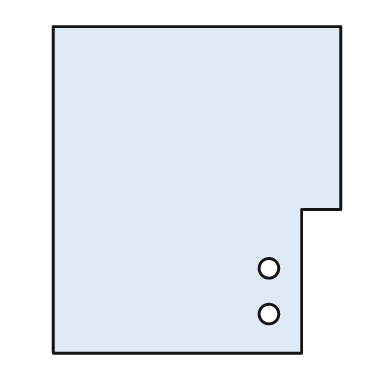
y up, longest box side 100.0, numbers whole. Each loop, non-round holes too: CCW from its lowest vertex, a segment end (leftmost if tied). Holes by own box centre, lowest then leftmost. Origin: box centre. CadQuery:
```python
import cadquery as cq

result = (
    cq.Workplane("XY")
    .moveTo(-44.0, -50.0)
    .lineTo(32.0, -50.0)
    .lineTo(32.0, -6.0)
    .lineTo(44.0, -6.0)
    .lineTo(44.0, 50.0)
    .lineTo(-44.0, 50.0)
    .close()
    .moveTo(22.0, -38.0)
    .circle(3.0)
    .moveTo(22.0, -24.0)
    .circle(3.0)
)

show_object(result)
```